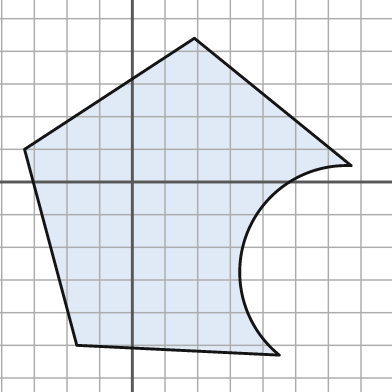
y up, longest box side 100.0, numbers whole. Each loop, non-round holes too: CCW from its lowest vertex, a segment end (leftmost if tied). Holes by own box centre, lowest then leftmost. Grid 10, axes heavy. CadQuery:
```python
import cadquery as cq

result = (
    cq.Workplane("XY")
    .moveTo(45.0, -53.0)
    .threePointArc((35.0, -16.0), (67.0, 5.0))
    .lineTo(19.0, 44.0)
    .lineTo(-33.0, 10.0)
    .lineTo(-17.0, -50.0)
    .close()
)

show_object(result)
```